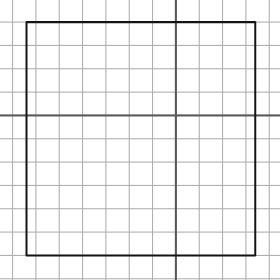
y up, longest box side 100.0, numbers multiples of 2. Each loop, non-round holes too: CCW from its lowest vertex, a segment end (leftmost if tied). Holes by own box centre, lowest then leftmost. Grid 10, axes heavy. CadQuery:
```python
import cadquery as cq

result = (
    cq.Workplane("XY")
    .moveTo(-64.0, -60.0)
    .lineTo(34.0, -60.0)
    .lineTo(34.0, 40.0)
    .lineTo(-64.0, 40.0)
    .close()
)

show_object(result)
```